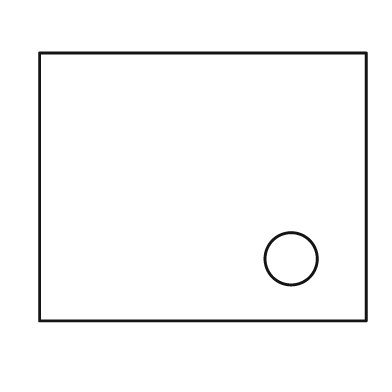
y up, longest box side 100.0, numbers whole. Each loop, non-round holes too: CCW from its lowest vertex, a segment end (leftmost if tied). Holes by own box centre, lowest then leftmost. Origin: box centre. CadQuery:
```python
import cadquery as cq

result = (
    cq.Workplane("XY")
    .moveTo(-50.0, -41.0)
    .lineTo(50.0, -41.0)
    .lineTo(50.0, 41.0)
    .lineTo(-50.0, 41.0)
    .close()
    .moveTo(27.0, -22.0)
    .circle(8.0)
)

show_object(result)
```